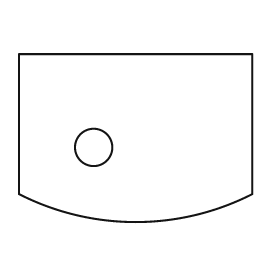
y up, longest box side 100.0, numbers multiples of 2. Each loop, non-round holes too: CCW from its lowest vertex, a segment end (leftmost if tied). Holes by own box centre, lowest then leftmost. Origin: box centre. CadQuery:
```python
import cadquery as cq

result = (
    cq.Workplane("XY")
    .moveTo(-50.0, -24.0)
    .threePointArc((0.0, -36.0), (50.0, -24.0))
    .lineTo(50.0, 36.0)
    .lineTo(-50.0, 36.0)
    .close()
    .moveTo(-18.0, -4.0)
    .circle(8.0)
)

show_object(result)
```